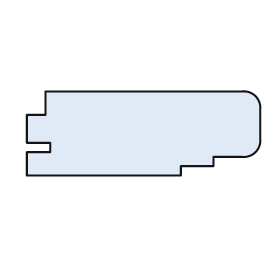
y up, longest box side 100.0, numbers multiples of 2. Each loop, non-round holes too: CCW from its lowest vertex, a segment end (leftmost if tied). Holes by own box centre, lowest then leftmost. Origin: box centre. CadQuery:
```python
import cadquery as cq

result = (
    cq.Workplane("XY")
    .moveTo(-50.0, -18.0)
    .lineTo(16.0, -18.0)
    .lineTo(16.0, -14.0)
    .lineTo(30.0, -14.0)
    .lineTo(30.0, -10.0)
    .lineTo(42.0, -10.0)
    .threePointArc((48.0, -8.0), (50.0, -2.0))
    .lineTo(50.0, 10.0)
    .threePointArc((48.0, 16.0), (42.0, 18.0))
    .lineTo(-42.0, 18.0)
    .lineTo(-42.0, 8.0)
    .lineTo(-50.0, 8.0)
    .lineTo(-50.0, -4.0)
    .lineTo(-40.0, -4.0)
    .lineTo(-40.0, -8.0)
    .lineTo(-50.0, -8.0)
    .close()
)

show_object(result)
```